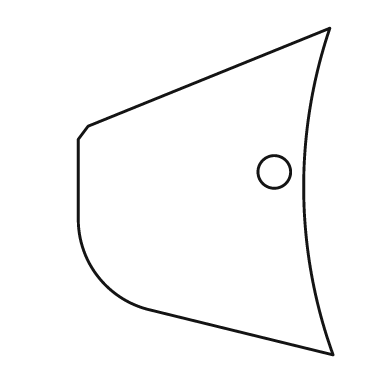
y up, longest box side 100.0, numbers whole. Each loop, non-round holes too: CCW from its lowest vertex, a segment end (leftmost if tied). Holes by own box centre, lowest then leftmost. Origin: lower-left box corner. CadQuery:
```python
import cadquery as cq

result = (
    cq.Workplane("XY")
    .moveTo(78.0, 0.0)
    .threePointArc((69.0, 50.0), (77.0, 100.0))
    .lineTo(3.0, 70.0)
    .lineTo(0.0, 66.0)
    .lineTo(0.0, 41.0)
    .threePointArc((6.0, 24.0), (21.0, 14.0))
    .close()
    .moveTo(60.0, 56.0)
    .circle(5.0)
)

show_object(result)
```